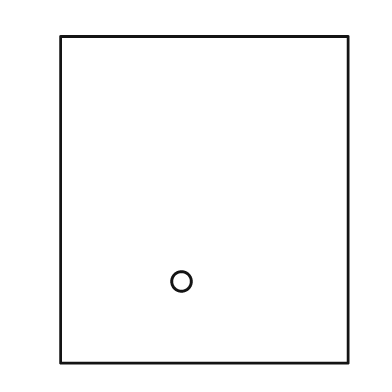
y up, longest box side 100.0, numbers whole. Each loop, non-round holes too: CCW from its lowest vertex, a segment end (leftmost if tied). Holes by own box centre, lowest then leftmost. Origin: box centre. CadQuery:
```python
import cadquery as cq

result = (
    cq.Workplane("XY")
    .moveTo(-44.0, -50.0)
    .lineTo(44.0, -50.0)
    .lineTo(44.0, 50.0)
    .lineTo(-44.0, 50.0)
    .close()
    .moveTo(-7.0, -25.0)
    .circle(3.0)
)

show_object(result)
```